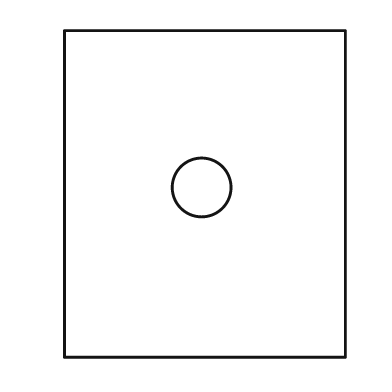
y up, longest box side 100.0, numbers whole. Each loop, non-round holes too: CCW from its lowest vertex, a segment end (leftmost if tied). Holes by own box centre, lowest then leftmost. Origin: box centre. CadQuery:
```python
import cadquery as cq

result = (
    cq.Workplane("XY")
    .moveTo(-43.0, -50.0)
    .lineTo(43.0, -50.0)
    .lineTo(43.0, 50.0)
    .lineTo(-43.0, 50.0)
    .close()
    .moveTo(-1.0, 2.0)
    .circle(9.0)
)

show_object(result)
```